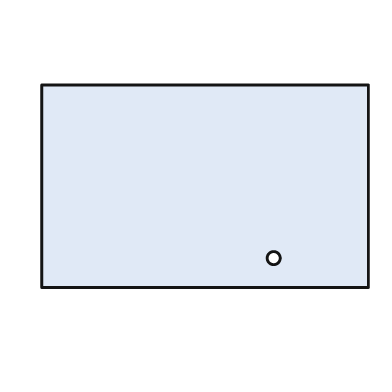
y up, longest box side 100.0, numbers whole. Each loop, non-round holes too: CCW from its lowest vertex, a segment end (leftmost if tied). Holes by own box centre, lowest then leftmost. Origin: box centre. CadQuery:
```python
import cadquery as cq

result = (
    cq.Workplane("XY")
    .moveTo(-50.0, -31.0)
    .lineTo(50.0, -31.0)
    .lineTo(50.0, 31.0)
    .lineTo(-50.0, 31.0)
    .close()
    .moveTo(21.0, -22.0)
    .circle(2.0)
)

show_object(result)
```